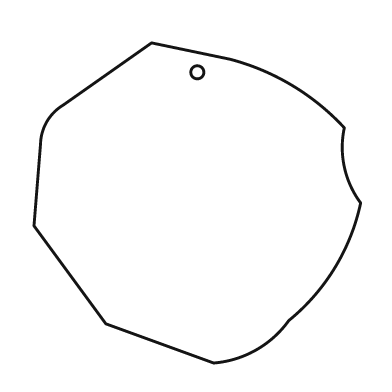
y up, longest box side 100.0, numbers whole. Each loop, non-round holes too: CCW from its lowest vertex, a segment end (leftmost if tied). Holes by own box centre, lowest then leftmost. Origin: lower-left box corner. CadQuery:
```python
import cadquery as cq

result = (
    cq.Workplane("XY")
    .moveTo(55.0, 0.0)
    .threePointArc((68.0, 4.0), (78.0, 13.0))
    .threePointArc((92.0, 29.0), (100.0, 49.0))
    .threePointArc((95.0, 60.0), (95.0, 72.0))
    .threePointArc((79.0, 85.0), (60.0, 93.0))
    .lineTo(36.0, 98.0)
    .lineTo(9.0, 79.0)
    .threePointArc((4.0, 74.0), (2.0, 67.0))
    .lineTo(0.0, 42.0)
    .lineTo(22.0, 12.0)
    .close()
    .moveTo(50.0, 89.0)
    .circle(2.0)
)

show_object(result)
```